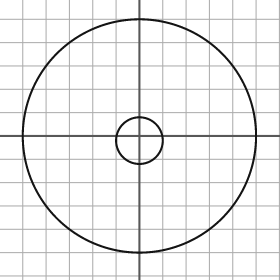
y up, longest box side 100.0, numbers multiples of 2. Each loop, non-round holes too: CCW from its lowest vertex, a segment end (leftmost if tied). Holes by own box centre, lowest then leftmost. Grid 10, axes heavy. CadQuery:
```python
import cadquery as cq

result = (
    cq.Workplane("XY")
    .moveTo(0.0, 0.0)
    .circle(50.0)
    .moveTo(0.0, -2.0)
    .circle(10.0)
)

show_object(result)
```